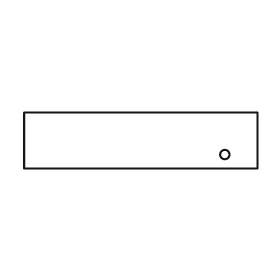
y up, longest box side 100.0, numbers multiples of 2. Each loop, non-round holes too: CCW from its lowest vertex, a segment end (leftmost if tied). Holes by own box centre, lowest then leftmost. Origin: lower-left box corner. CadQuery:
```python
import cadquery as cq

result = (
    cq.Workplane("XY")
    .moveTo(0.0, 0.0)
    .lineTo(100.0, 0.0)
    .lineTo(100.0, 24.0)
    .lineTo(0.0, 24.0)
    .close()
    .moveTo(86.0, 6.0)
    .circle(2.0)
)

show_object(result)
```